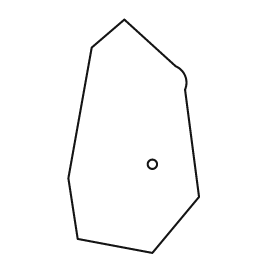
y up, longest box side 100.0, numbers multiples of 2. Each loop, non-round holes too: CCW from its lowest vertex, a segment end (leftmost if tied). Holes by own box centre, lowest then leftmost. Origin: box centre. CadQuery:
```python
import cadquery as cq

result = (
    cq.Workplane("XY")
    .moveTo(8.0, -50.0)
    .lineTo(28.0, -26.0)
    .lineTo(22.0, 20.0)
    .threePointArc((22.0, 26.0), (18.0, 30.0))
    .lineTo(-4.0, 50.0)
    .lineTo(-18.0, 38.0)
    .lineTo(-28.0, -18.0)
    .lineTo(-24.0, -44.0)
    .close()
    .moveTo(8.0, -12.0)
    .circle(2.0)
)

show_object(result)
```